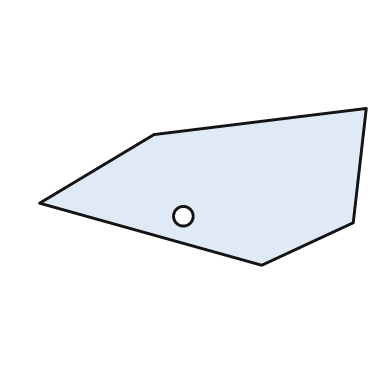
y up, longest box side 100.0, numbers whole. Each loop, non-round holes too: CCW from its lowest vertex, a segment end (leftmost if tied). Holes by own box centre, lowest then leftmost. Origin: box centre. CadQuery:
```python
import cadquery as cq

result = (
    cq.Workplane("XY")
    .moveTo(18.0, -24.0)
    .lineTo(46.0, -11.0)
    .lineTo(50.0, 24.0)
    .lineTo(-15.0, 16.0)
    .lineTo(-50.0, -5.0)
    .close()
    .moveTo(-6.0, -9.0)
    .circle(3.0)
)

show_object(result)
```